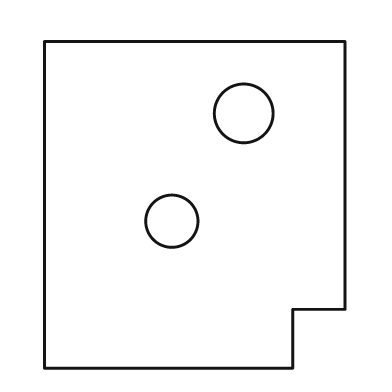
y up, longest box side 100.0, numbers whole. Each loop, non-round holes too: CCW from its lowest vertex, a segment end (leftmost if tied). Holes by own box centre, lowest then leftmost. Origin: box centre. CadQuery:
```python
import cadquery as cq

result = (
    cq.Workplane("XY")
    .moveTo(-46.0, -50.0)
    .lineTo(30.0, -50.0)
    .lineTo(30.0, -32.0)
    .lineTo(46.0, -32.0)
    .lineTo(46.0, 50.0)
    .lineTo(-46.0, 50.0)
    .close()
    .moveTo(-7.0, -5.0)
    .circle(8.0)
    .moveTo(15.0, 28.0)
    .circle(9.0)
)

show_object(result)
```